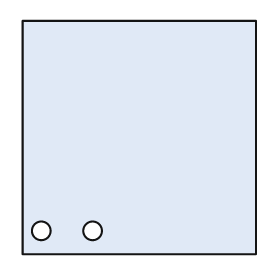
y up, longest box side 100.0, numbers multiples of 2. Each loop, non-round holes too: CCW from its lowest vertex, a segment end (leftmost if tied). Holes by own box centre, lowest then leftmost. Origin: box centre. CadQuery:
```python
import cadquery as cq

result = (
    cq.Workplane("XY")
    .moveTo(-50.0, -50.0)
    .lineTo(50.0, -50.0)
    .lineTo(50.0, 50.0)
    .lineTo(-50.0, 50.0)
    .close()
    .moveTo(-42.0, -40.0)
    .circle(4.0)
    .moveTo(-20.0, -40.0)
    .circle(4.0)
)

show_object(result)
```